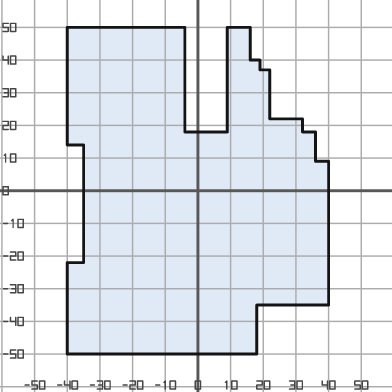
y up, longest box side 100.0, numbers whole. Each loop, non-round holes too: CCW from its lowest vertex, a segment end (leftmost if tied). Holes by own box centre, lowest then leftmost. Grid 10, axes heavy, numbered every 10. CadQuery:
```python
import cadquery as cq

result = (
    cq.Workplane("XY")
    .moveTo(-40.0, -50.0)
    .lineTo(18.0, -50.0)
    .lineTo(18.0, -35.0)
    .lineTo(40.0, -35.0)
    .lineTo(40.0, 9.0)
    .lineTo(36.0, 9.0)
    .lineTo(36.0, 18.0)
    .lineTo(32.0, 18.0)
    .lineTo(32.0, 22.0)
    .lineTo(22.0, 22.0)
    .lineTo(22.0, 37.0)
    .lineTo(19.0, 37.0)
    .lineTo(19.0, 40.0)
    .lineTo(16.0, 40.0)
    .lineTo(16.0, 50.0)
    .lineTo(9.0, 50.0)
    .lineTo(9.0, 18.0)
    .lineTo(-4.0, 18.0)
    .lineTo(-4.0, 50.0)
    .lineTo(-40.0, 50.0)
    .lineTo(-40.0, 14.0)
    .lineTo(-35.0, 14.0)
    .lineTo(-35.0, -22.0)
    .lineTo(-40.0, -22.0)
    .close()
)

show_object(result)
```